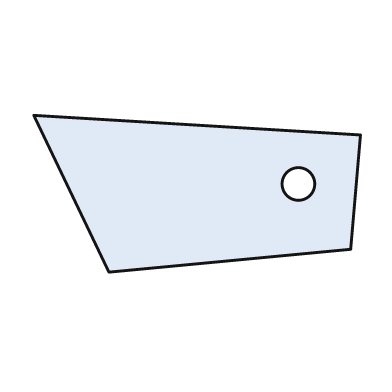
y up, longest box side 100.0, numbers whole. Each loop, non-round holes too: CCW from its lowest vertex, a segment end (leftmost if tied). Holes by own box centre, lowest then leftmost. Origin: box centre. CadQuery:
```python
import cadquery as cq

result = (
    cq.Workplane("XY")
    .moveTo(-27.0, -24.0)
    .lineTo(47.0, -17.0)
    .lineTo(50.0, 18.0)
    .lineTo(-50.0, 24.0)
    .close()
    .moveTo(31.0, 3.0)
    .circle(5.0)
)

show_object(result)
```